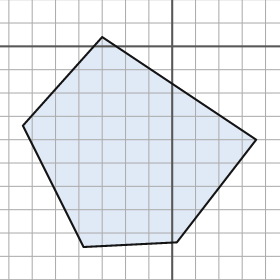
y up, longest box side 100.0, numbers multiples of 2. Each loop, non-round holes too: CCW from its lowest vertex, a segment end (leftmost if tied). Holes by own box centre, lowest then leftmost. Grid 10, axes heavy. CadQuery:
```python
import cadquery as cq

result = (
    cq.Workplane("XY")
    .moveTo(-38.0, -86.0)
    .lineTo(2.0, -84.0)
    .lineTo(36.0, -40.0)
    .lineTo(-30.0, 4.0)
    .lineTo(-64.0, -34.0)
    .close()
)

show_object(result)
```